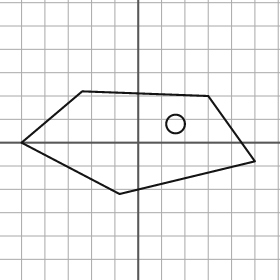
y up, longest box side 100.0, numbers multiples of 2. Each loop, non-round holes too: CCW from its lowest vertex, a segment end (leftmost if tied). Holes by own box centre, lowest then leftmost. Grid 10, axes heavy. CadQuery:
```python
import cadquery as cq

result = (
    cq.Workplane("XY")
    .moveTo(-8.0, -22.0)
    .lineTo(50.0, -8.0)
    .lineTo(30.0, 20.0)
    .lineTo(-24.0, 22.0)
    .lineTo(-50.0, 0.0)
    .close()
    .moveTo(16.0, 8.0)
    .circle(4.0)
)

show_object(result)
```